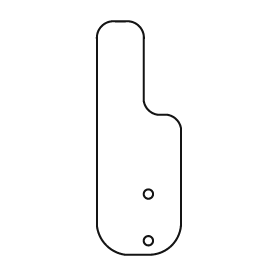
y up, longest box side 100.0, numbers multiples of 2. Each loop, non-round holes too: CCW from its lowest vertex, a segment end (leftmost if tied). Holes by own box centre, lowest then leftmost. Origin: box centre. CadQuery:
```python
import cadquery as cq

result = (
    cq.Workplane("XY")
    .moveTo(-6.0, -50.0)
    .lineTo(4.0, -50.0)
    .threePointArc((14.0, -46.0), (18.0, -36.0))
    .lineTo(18.0, 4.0)
    .threePointArc((16.0, 8.0), (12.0, 10.0))
    .lineTo(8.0, 10.0)
    .threePointArc((4.0, 12.0), (2.0, 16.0))
    .lineTo(2.0, 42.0)
    .threePointArc((0.0, 48.0), (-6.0, 50.0))
    .lineTo(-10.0, 50.0)
    .threePointArc((-16.0, 48.0), (-18.0, 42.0))
    .lineTo(-18.0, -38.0)
    .threePointArc((-14.0, -46.0), (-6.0, -50.0))
    .close()
    .moveTo(4.0, -44.0)
    .circle(2.0)
    .moveTo(4.0, -24.0)
    .circle(2.0)
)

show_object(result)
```